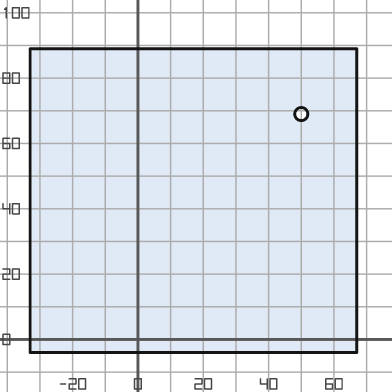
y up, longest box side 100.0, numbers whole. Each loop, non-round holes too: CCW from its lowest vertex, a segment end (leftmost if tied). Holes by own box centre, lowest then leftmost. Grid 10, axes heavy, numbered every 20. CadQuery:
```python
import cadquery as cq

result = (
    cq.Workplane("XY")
    .moveTo(-33.0, -4.0)
    .lineTo(67.0, -4.0)
    .lineTo(67.0, 89.0)
    .lineTo(-33.0, 89.0)
    .close()
    .moveTo(50.0, 69.0)
    .circle(2.0)
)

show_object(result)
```